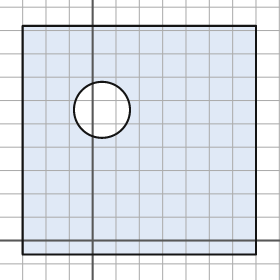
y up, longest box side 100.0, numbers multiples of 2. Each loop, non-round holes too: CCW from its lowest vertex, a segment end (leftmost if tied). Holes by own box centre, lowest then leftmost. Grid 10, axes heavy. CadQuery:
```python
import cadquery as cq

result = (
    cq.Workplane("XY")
    .moveTo(-30.0, -6.0)
    .lineTo(70.0, -6.0)
    .lineTo(70.0, 92.0)
    .lineTo(-30.0, 92.0)
    .close()
    .moveTo(4.0, 56.0)
    .circle(12.0)
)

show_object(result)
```